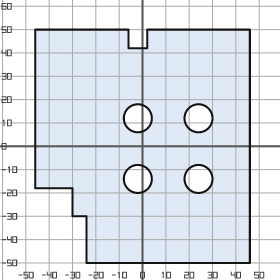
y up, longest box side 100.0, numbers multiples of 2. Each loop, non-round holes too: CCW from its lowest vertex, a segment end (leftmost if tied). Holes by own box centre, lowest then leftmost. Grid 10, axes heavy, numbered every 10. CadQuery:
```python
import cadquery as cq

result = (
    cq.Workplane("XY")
    .moveTo(-24.0, -50.0)
    .lineTo(46.0, -50.0)
    .lineTo(46.0, 50.0)
    .lineTo(2.0, 50.0)
    .lineTo(2.0, 42.0)
    .lineTo(-6.0, 42.0)
    .lineTo(-6.0, 50.0)
    .lineTo(-46.0, 50.0)
    .lineTo(-46.0, -18.0)
    .lineTo(-30.0, -18.0)
    .lineTo(-30.0, -30.0)
    .lineTo(-24.0, -30.0)
    .close()
    .moveTo(-2.0, -14.0)
    .circle(6.0)
    .moveTo(24.0, -14.0)
    .circle(6.0)
    .moveTo(-2.0, 12.0)
    .circle(6.0)
    .moveTo(24.0, 12.0)
    .circle(6.0)
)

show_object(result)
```